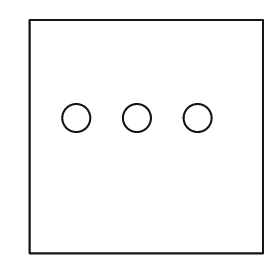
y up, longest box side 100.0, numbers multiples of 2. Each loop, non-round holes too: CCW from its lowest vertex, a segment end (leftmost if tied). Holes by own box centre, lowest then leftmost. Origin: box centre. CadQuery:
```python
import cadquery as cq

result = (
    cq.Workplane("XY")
    .moveTo(-50.0, -50.0)
    .lineTo(50.0, -50.0)
    .lineTo(50.0, 50.0)
    .lineTo(-50.0, 50.0)
    .close()
    .moveTo(-30.0, 8.0)
    .circle(6.0)
    .moveTo(-4.0, 8.0)
    .circle(6.0)
    .moveTo(22.0, 8.0)
    .circle(6.0)
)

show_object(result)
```